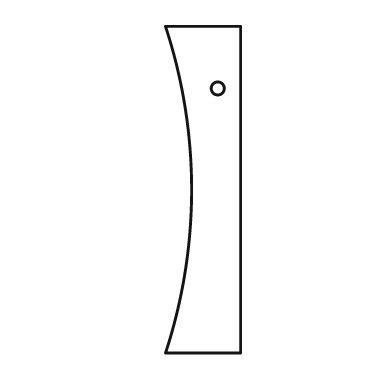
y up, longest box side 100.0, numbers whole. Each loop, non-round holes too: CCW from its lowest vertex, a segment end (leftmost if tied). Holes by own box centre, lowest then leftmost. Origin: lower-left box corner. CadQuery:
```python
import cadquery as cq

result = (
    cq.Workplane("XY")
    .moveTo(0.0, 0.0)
    .lineTo(23.0, 0.0)
    .lineTo(23.0, 100.0)
    .lineTo(0.0, 100.0)
    .threePointArc((8.0, 50.0), (0.0, 0.0))
    .close()
    .moveTo(16.0, 81.0)
    .circle(2.0)
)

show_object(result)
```